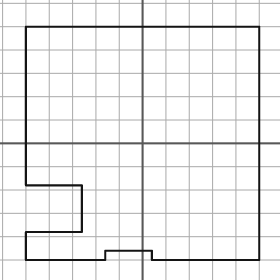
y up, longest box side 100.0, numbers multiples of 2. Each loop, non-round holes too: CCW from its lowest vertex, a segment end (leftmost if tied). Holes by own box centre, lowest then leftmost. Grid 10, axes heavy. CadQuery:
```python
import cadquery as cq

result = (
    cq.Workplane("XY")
    .moveTo(-50.0, -50.0)
    .lineTo(-16.0, -50.0)
    .lineTo(-16.0, -46.0)
    .lineTo(4.0, -46.0)
    .lineTo(4.0, -50.0)
    .lineTo(50.0, -50.0)
    .lineTo(50.0, 50.0)
    .lineTo(-50.0, 50.0)
    .lineTo(-50.0, -18.0)
    .lineTo(-26.0, -18.0)
    .lineTo(-26.0, -38.0)
    .lineTo(-50.0, -38.0)
    .close()
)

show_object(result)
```